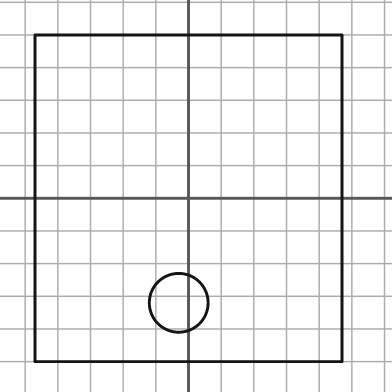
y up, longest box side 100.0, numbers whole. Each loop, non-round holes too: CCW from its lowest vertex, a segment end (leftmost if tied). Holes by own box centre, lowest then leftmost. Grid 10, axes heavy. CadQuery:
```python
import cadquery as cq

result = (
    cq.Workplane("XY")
    .moveTo(-47.0, -50.0)
    .lineTo(47.0, -50.0)
    .lineTo(47.0, 50.0)
    .lineTo(-47.0, 50.0)
    .close()
    .moveTo(-3.0, -32.0)
    .circle(9.0)
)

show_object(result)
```